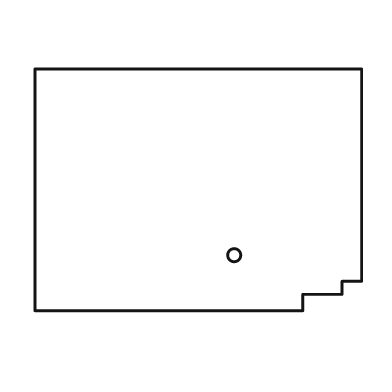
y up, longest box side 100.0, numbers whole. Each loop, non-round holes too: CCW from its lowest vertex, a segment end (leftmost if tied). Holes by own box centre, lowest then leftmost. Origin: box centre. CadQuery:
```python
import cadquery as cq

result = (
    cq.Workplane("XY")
    .moveTo(-50.0, -37.0)
    .lineTo(32.0, -37.0)
    .lineTo(32.0, -32.0)
    .lineTo(44.0, -32.0)
    .lineTo(44.0, -28.0)
    .lineTo(50.0, -28.0)
    .lineTo(50.0, 37.0)
    .lineTo(-50.0, 37.0)
    .close()
    .moveTo(11.0, -20.0)
    .circle(2.0)
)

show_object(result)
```